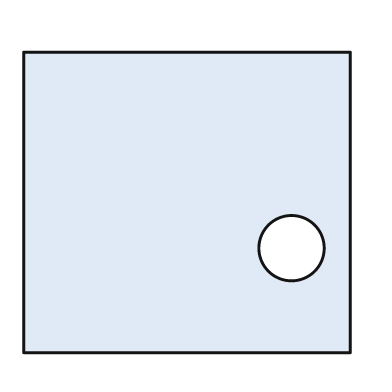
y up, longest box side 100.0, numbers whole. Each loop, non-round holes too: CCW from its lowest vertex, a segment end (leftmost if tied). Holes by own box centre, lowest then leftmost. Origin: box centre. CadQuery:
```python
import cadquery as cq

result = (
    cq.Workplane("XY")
    .moveTo(-50.0, -46.0)
    .lineTo(50.0, -46.0)
    .lineTo(50.0, 46.0)
    .lineTo(-50.0, 46.0)
    .close()
    .moveTo(32.0, -14.0)
    .circle(10.0)
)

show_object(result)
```